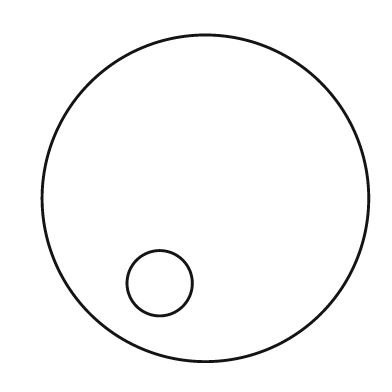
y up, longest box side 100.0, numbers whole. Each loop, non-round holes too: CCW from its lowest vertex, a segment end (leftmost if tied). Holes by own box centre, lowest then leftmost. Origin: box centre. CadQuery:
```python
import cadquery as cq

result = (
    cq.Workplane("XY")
    .moveTo(0.0, 0.0)
    .circle(50.0)
    .moveTo(-14.0, -26.0)
    .circle(10.0)
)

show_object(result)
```